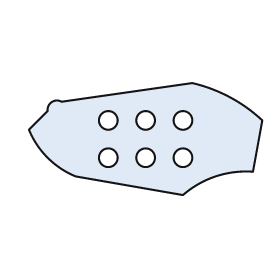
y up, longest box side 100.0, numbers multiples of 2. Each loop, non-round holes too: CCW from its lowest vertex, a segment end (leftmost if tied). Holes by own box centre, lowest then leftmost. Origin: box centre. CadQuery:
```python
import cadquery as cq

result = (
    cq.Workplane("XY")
    .moveTo(16.0, -24.0)
    .threePointArc((30.0, -16.0), (46.0, -14.0))
    .lineTo(50.0, 8.0)
    .threePointArc((36.0, 18.0), (20.0, 24.0))
    .lineTo(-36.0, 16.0)
    .threePointArc((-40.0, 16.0), (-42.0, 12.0))
    .lineTo(-50.0, 4.0)
    .threePointArc((-42.0, -8.0), (-30.0, -16.0))
    .close()
    .moveTo(-16.0, -8.0)
    .circle(4.0)
    .moveTo(0.0, -8.0)
    .circle(4.0)
    .moveTo(16.0, -8.0)
    .circle(4.0)
    .moveTo(-16.0, 8.0)
    .circle(4.0)
    .moveTo(0.0, 8.0)
    .circle(4.0)
    .moveTo(16.0, 8.0)
    .circle(4.0)
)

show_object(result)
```